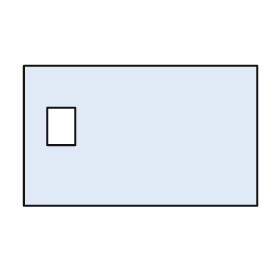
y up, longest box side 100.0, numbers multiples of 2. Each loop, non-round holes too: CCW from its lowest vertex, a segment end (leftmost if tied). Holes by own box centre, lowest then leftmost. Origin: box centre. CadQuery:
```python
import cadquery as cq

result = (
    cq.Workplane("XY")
    .moveTo(-50.0, -30.0)
    .lineTo(50.0, -30.0)
    .lineTo(50.0, 30.0)
    .lineTo(-50.0, 30.0)
    .close()
    .moveTo(-40.0, -4.0)
    .lineTo(-28.0, -4.0)
    .lineTo(-28.0, 12.0)
    .lineTo(-40.0, 12.0)
    .close()
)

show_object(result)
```